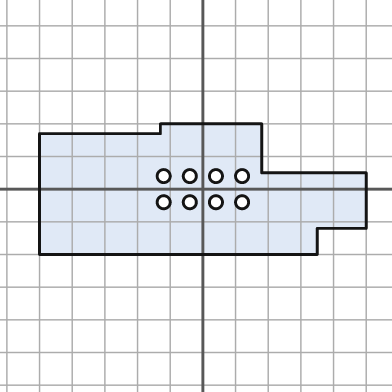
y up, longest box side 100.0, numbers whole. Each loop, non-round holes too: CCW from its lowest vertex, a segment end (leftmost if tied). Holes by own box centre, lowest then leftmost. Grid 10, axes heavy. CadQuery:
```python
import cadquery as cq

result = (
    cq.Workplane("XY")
    .moveTo(-50.0, -20.0)
    .lineTo(35.0, -20.0)
    .lineTo(35.0, -12.0)
    .lineTo(50.0, -12.0)
    .lineTo(50.0, 5.0)
    .lineTo(18.0, 5.0)
    .lineTo(18.0, 20.0)
    .lineTo(-13.0, 20.0)
    .lineTo(-13.0, 17.0)
    .lineTo(-50.0, 17.0)
    .close()
    .moveTo(-12.0, -4.0)
    .circle(2.0)
    .moveTo(-4.0, -4.0)
    .circle(2.0)
    .moveTo(4.0, -4.0)
    .circle(2.0)
    .moveTo(12.0, -4.0)
    .circle(2.0)
    .moveTo(-12.0, 4.0)
    .circle(2.0)
    .moveTo(-4.0, 4.0)
    .circle(2.0)
    .moveTo(4.0, 4.0)
    .circle(2.0)
    .moveTo(12.0, 4.0)
    .circle(2.0)
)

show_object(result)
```